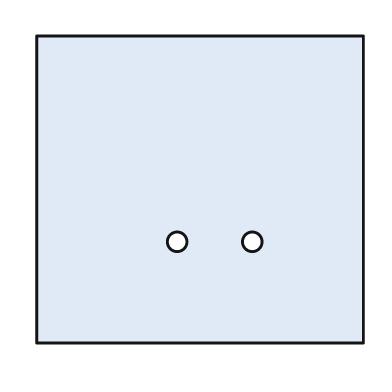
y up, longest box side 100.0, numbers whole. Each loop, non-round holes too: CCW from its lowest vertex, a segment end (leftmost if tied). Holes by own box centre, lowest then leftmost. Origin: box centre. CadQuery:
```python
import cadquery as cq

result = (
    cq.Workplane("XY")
    .moveTo(-50.0, -47.0)
    .lineTo(50.0, -47.0)
    .lineTo(50.0, 47.0)
    .lineTo(-50.0, 47.0)
    .close()
    .moveTo(-7.0, -16.0)
    .circle(3.0)
    .moveTo(16.0, -16.0)
    .circle(3.0)
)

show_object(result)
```